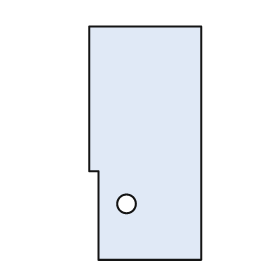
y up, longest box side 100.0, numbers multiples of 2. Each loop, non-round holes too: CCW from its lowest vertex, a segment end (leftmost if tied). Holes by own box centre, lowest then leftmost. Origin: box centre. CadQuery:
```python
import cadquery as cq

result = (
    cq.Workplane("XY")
    .moveTo(-20.0, -50.0)
    .lineTo(24.0, -50.0)
    .lineTo(24.0, 50.0)
    .lineTo(-24.0, 50.0)
    .lineTo(-24.0, -12.0)
    .lineTo(-20.0, -12.0)
    .close()
    .moveTo(-8.0, -26.0)
    .circle(4.0)
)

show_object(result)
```